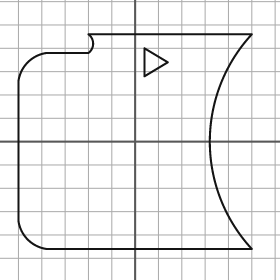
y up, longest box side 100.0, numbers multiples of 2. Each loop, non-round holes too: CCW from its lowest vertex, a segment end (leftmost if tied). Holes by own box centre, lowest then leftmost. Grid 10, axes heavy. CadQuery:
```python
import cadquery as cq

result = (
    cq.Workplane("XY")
    .moveTo(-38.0, -46.0)
    .lineTo(50.0, -46.0)
    .threePointArc((32.0, 0.0), (50.0, 46.0))
    .lineTo(-20.0, 46.0)
    .threePointArc((-18.0, 42.0), (-20.0, 38.0))
    .lineTo(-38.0, 38.0)
    .threePointArc((-46.0, 34.0), (-50.0, 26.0))
    .lineTo(-50.0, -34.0)
    .threePointArc((-46.0, -42.0), (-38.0, -46.0))
    .close()
    .moveTo(4.0, 28.0)
    .lineTo(14.0, 34.0)
    .lineTo(4.0, 40.0)
    .close()
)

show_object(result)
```